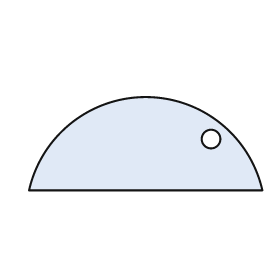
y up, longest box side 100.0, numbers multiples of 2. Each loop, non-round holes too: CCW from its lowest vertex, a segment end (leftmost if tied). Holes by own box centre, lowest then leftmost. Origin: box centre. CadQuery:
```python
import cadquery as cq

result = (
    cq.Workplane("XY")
    .moveTo(-50.0, -20.0)
    .lineTo(50.0, -20.0)
    .threePointArc((0.0, 20.0), (-50.0, -20.0))
    .close()
    .moveTo(28.0, 2.0)
    .circle(4.0)
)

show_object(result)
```